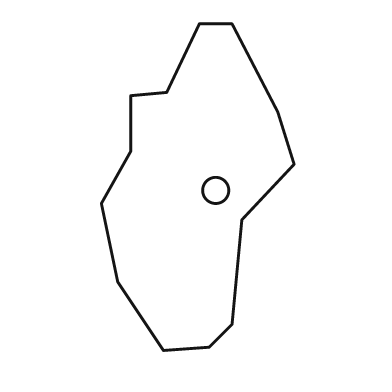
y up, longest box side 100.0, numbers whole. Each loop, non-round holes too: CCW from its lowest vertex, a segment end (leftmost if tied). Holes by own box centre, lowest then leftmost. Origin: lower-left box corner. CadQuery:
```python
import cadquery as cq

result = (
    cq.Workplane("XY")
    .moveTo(19.0, 0.0)
    .lineTo(33.0, 1.0)
    .lineTo(40.0, 8.0)
    .lineTo(43.0, 40.0)
    .lineTo(59.0, 57.0)
    .lineTo(54.0, 73.0)
    .lineTo(40.0, 100.0)
    .lineTo(30.0, 100.0)
    .lineTo(20.0, 79.0)
    .lineTo(9.0, 78.0)
    .lineTo(9.0, 61.0)
    .lineTo(0.0, 45.0)
    .lineTo(5.0, 21.0)
    .close()
    .moveTo(35.0, 49.0)
    .circle(4.0)
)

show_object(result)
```